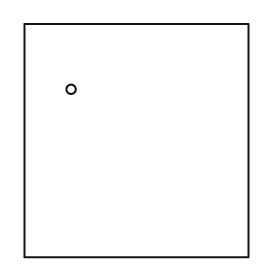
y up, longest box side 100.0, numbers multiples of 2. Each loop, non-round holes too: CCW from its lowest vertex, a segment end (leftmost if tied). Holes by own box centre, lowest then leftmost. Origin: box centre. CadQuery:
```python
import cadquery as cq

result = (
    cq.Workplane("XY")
    .moveTo(-48.0, -50.0)
    .lineTo(48.0, -50.0)
    .lineTo(48.0, 50.0)
    .lineTo(-48.0, 50.0)
    .close()
    .moveTo(-28.0, 22.0)
    .circle(2.0)
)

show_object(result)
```